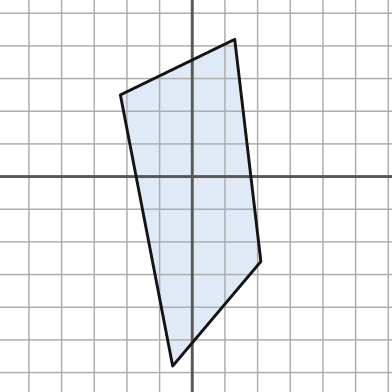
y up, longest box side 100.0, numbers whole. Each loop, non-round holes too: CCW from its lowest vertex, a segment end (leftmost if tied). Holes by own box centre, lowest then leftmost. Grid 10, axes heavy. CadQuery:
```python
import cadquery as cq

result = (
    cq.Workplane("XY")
    .moveTo(-6.0, -58.0)
    .lineTo(21.0, -26.0)
    .lineTo(13.0, 42.0)
    .lineTo(-22.0, 25.0)
    .close()
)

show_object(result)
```